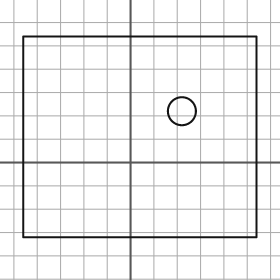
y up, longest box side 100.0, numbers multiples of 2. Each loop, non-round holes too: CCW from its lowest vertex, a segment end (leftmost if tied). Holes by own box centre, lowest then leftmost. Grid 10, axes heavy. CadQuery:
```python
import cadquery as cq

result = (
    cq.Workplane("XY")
    .moveTo(-46.0, -32.0)
    .lineTo(54.0, -32.0)
    .lineTo(54.0, 54.0)
    .lineTo(-46.0, 54.0)
    .close()
    .moveTo(22.0, 22.0)
    .circle(6.0)
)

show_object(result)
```